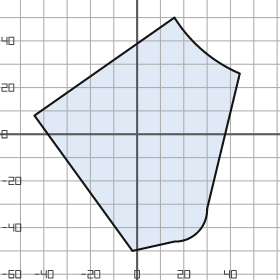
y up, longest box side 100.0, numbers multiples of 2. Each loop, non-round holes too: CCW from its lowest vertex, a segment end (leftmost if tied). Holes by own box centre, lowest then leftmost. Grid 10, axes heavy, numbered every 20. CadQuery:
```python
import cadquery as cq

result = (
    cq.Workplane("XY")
    .moveTo(-2.0, -50.0)
    .lineTo(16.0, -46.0)
    .threePointArc((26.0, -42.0), (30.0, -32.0))
    .lineTo(44.0, 26.0)
    .threePointArc((28.0, 36.0), (16.0, 50.0))
    .lineTo(-44.0, 8.0)
    .close()
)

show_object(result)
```